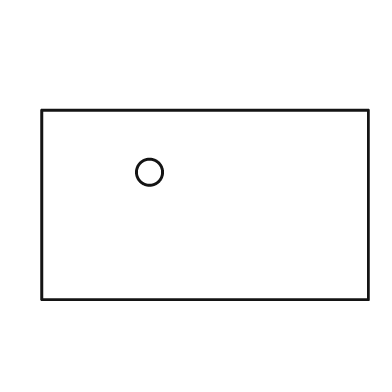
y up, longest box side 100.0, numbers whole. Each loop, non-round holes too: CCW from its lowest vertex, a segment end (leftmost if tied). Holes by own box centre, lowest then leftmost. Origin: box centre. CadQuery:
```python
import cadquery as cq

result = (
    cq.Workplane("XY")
    .moveTo(-50.0, -29.0)
    .lineTo(50.0, -29.0)
    .lineTo(50.0, 29.0)
    .lineTo(-50.0, 29.0)
    .close()
    .moveTo(-17.0, 10.0)
    .circle(4.0)
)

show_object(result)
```